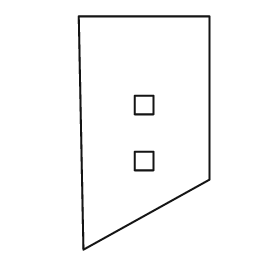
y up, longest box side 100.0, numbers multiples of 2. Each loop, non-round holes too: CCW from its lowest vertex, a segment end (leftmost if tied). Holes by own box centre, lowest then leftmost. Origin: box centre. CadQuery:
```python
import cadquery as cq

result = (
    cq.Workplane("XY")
    .moveTo(-26.0, -50.0)
    .lineTo(28.0, -20.0)
    .lineTo(28.0, 50.0)
    .lineTo(-28.0, 50.0)
    .close()
    .moveTo(-4.0, -16.0)
    .lineTo(4.0, -16.0)
    .lineTo(4.0, -8.0)
    .lineTo(-4.0, -8.0)
    .close()
    .moveTo(-4.0, 8.0)
    .lineTo(4.0, 8.0)
    .lineTo(4.0, 16.0)
    .lineTo(-4.0, 16.0)
    .close()
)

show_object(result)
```